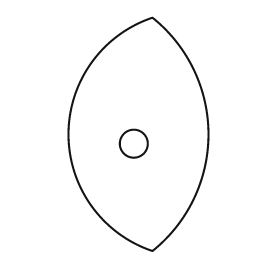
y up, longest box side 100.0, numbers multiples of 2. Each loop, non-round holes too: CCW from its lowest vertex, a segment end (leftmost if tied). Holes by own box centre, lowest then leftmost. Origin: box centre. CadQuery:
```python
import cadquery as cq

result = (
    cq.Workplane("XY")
    .moveTo(6.0, -50.0)
    .threePointArc((30.0, 0.0), (6.0, 50.0))
    .threePointArc((-30.0, 0.0), (6.0, -50.0))
    .close()
    .moveTo(-2.0, -4.0)
    .circle(6.0)
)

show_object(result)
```